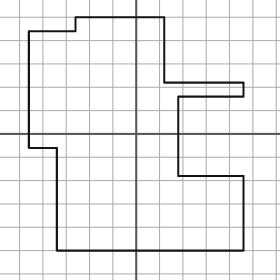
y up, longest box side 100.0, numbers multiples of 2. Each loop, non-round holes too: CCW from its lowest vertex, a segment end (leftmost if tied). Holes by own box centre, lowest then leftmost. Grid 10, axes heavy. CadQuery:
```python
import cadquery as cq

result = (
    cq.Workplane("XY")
    .moveTo(-34.0, -50.0)
    .lineTo(46.0, -50.0)
    .lineTo(46.0, -18.0)
    .lineTo(18.0, -18.0)
    .lineTo(18.0, 16.0)
    .lineTo(46.0, 16.0)
    .lineTo(46.0, 22.0)
    .lineTo(12.0, 22.0)
    .lineTo(12.0, 50.0)
    .lineTo(-26.0, 50.0)
    .lineTo(-26.0, 44.0)
    .lineTo(-46.0, 44.0)
    .lineTo(-46.0, -6.0)
    .lineTo(-34.0, -6.0)
    .close()
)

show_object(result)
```